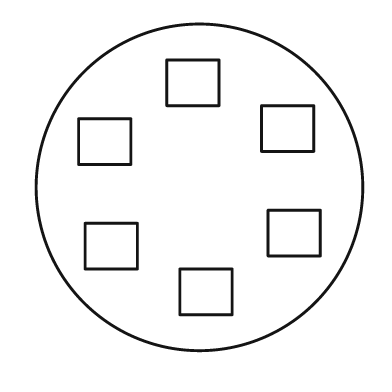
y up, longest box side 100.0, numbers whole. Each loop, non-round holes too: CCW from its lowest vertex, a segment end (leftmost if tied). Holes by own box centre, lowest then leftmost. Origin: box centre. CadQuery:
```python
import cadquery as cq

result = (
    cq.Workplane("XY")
    .moveTo(0.0, 0.0)
    .circle(50.0)
    .moveTo(-6.0, -39.0)
    .lineTo(10.0, -39.0)
    .lineTo(10.0, -25.0)
    .lineTo(-6.0, -25.0)
    .close()
    .moveTo(-35.0, -25.0)
    .lineTo(-19.0, -25.0)
    .lineTo(-19.0, -11.0)
    .lineTo(-35.0, -11.0)
    .close()
    .moveTo(21.0, -21.0)
    .lineTo(37.0, -21.0)
    .lineTo(37.0, -7.0)
    .lineTo(21.0, -7.0)
    .close()
    .moveTo(-37.0, 7.0)
    .lineTo(-21.0, 7.0)
    .lineTo(-21.0, 21.0)
    .lineTo(-37.0, 21.0)
    .close()
    .moveTo(19.0, 11.0)
    .lineTo(35.0, 11.0)
    .lineTo(35.0, 25.0)
    .lineTo(19.0, 25.0)
    .close()
    .moveTo(-10.0, 25.0)
    .lineTo(6.0, 25.0)
    .lineTo(6.0, 39.0)
    .lineTo(-10.0, 39.0)
    .close()
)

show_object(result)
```